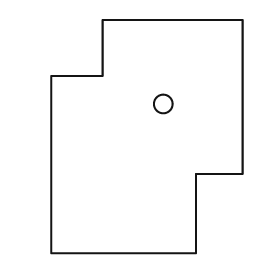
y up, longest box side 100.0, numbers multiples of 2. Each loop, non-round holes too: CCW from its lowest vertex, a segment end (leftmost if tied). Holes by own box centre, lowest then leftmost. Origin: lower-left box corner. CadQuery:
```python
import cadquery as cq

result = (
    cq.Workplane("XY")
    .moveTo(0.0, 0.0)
    .lineTo(62.0, 0.0)
    .lineTo(62.0, 34.0)
    .lineTo(82.0, 34.0)
    .lineTo(82.0, 100.0)
    .lineTo(22.0, 100.0)
    .lineTo(22.0, 76.0)
    .lineTo(0.0, 76.0)
    .close()
    .moveTo(48.0, 64.0)
    .circle(4.0)
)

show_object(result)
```